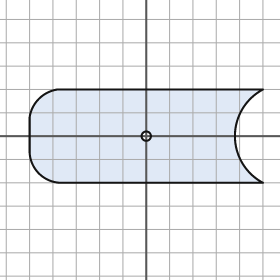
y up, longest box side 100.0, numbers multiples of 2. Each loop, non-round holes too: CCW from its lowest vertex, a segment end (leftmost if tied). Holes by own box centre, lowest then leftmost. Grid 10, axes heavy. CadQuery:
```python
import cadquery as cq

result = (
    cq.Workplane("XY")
    .moveTo(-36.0, -20.0)
    .lineTo(50.0, -20.0)
    .threePointArc((38.0, 0.0), (50.0, 20.0))
    .lineTo(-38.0, 20.0)
    .threePointArc((-46.0, 16.0), (-50.0, 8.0))
    .lineTo(-50.0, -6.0)
    .threePointArc((-46.0, -16.0), (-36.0, -20.0))
    .close()
    .moveTo(0.0, 0.0)
    .circle(2.0)
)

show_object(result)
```